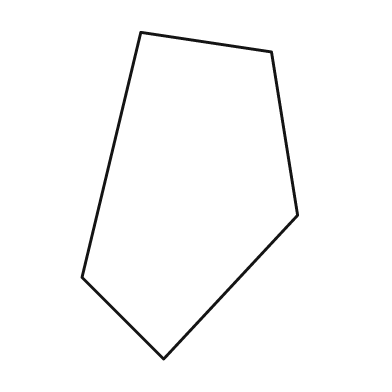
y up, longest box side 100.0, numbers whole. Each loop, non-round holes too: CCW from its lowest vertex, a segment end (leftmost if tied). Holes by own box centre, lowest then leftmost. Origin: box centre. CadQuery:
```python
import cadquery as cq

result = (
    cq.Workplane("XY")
    .moveTo(-8.0, -50.0)
    .lineTo(33.0, -6.0)
    .lineTo(25.0, 44.0)
    .lineTo(-15.0, 50.0)
    .lineTo(-33.0, -25.0)
    .close()
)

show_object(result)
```